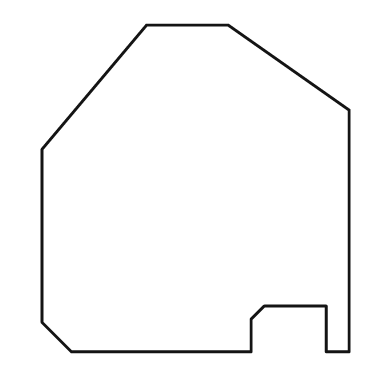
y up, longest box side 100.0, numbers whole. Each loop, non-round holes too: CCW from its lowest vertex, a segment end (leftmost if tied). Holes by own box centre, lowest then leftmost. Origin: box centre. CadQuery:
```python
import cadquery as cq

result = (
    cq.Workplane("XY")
    .moveTo(-38.0, -50.0)
    .lineTo(17.0, -50.0)
    .lineTo(17.0, -40.0)
    .lineTo(21.0, -36.0)
    .lineTo(40.0, -36.0)
    .lineTo(40.0, -50.0)
    .lineTo(47.0, -50.0)
    .lineTo(47.0, 24.0)
    .lineTo(10.0, 50.0)
    .lineTo(-15.0, 50.0)
    .lineTo(-47.0, 12.0)
    .lineTo(-47.0, -41.0)
    .close()
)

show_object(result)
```